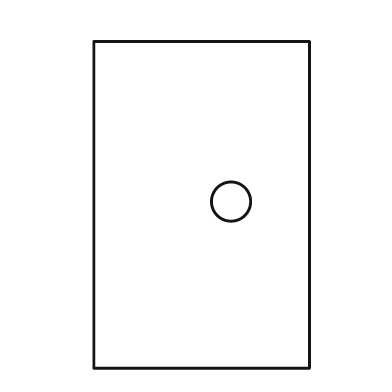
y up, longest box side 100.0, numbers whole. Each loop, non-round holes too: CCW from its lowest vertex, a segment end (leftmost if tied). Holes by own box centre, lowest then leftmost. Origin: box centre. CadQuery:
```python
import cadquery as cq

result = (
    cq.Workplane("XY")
    .moveTo(-33.0, -50.0)
    .lineTo(33.0, -50.0)
    .lineTo(33.0, 50.0)
    .lineTo(-33.0, 50.0)
    .close()
    .moveTo(9.0, 1.0)
    .circle(6.0)
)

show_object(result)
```